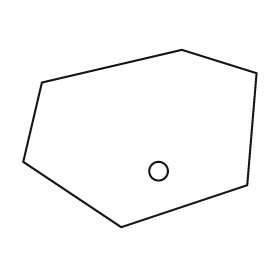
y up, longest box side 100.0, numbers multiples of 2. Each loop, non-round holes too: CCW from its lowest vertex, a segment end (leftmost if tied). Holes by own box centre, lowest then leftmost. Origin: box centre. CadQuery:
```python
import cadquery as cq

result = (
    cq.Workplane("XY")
    .moveTo(-8.0, -38.0)
    .lineTo(46.0, -20.0)
    .lineTo(50.0, 28.0)
    .lineTo(18.0, 38.0)
    .lineTo(-42.0, 24.0)
    .lineTo(-50.0, -10.0)
    .close()
    .moveTo(8.0, -14.0)
    .circle(4.0)
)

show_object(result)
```